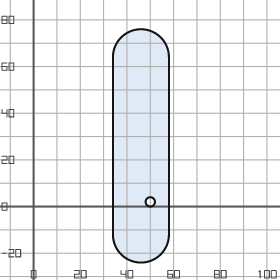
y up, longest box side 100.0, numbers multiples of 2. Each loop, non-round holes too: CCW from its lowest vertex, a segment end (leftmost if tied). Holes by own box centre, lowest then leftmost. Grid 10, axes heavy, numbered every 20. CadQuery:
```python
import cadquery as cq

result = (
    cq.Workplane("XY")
    .moveTo(34.0, -12.0)
    .threePointArc((46.0, -24.0), (58.0, -12.0))
    .lineTo(58.0, 64.0)
    .threePointArc((46.0, 76.0), (34.0, 64.0))
    .close()
    .moveTo(50.0, 2.0)
    .circle(2.0)
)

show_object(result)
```